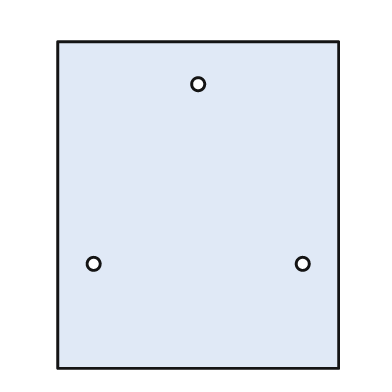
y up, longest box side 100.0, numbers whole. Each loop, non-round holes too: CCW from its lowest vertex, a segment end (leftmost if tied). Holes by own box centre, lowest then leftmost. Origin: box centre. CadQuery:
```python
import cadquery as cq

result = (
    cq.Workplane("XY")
    .moveTo(-43.0, -50.0)
    .lineTo(43.0, -50.0)
    .lineTo(43.0, 50.0)
    .lineTo(-43.0, 50.0)
    .close()
    .moveTo(-32.0, -18.0)
    .circle(2.0)
    .moveTo(32.0, -18.0)
    .circle(2.0)
    .moveTo(0.0, 37.0)
    .circle(2.0)
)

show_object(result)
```